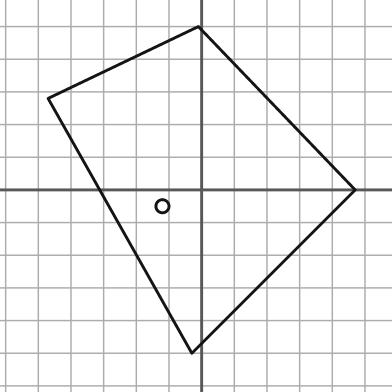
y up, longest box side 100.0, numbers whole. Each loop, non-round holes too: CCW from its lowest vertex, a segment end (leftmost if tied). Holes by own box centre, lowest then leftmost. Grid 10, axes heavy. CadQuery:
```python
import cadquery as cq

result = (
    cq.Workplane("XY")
    .moveTo(-3.0, -50.0)
    .lineTo(47.0, 0.0)
    .lineTo(-1.0, 50.0)
    .lineTo(-47.0, 28.0)
    .close()
    .moveTo(-12.0, -5.0)
    .circle(2.0)
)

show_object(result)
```